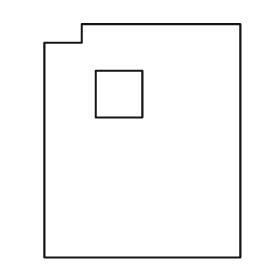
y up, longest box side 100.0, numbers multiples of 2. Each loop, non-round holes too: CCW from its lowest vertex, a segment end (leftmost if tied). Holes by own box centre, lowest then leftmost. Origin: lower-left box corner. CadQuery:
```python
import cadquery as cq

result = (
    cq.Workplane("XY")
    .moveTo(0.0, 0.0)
    .lineTo(84.0, 0.0)
    .lineTo(84.0, 100.0)
    .lineTo(16.0, 100.0)
    .lineTo(16.0, 92.0)
    .lineTo(0.0, 92.0)
    .close()
    .moveTo(22.0, 60.0)
    .lineTo(42.0, 60.0)
    .lineTo(42.0, 80.0)
    .lineTo(22.0, 80.0)
    .close()
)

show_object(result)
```